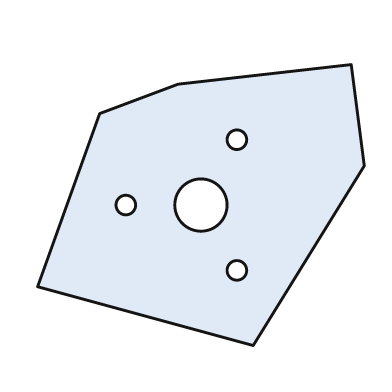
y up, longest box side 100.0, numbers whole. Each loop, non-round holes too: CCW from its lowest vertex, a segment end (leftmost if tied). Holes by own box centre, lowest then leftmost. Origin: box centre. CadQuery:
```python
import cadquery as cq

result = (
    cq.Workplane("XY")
    .moveTo(16.0, -43.0)
    .lineTo(50.0, 12.0)
    .lineTo(46.0, 43.0)
    .lineTo(-7.0, 37.0)
    .lineTo(-31.0, 28.0)
    .lineTo(-50.0, -25.0)
    .close()
    .moveTo(11.0, -20.0)
    .circle(3.0)
    .moveTo(-23.0, 0.0)
    .circle(3.0)
    .moveTo(0.0, 0.0)
    .circle(8.0)
    .moveTo(11.0, 20.0)
    .circle(3.0)
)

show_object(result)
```